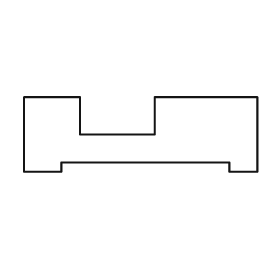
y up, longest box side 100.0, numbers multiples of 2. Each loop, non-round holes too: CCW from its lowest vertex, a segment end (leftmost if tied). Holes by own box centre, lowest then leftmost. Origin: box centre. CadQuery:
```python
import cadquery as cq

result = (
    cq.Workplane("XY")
    .moveTo(-50.0, -16.0)
    .lineTo(-34.0, -16.0)
    .lineTo(-34.0, -12.0)
    .lineTo(38.0, -12.0)
    .lineTo(38.0, -16.0)
    .lineTo(50.0, -16.0)
    .lineTo(50.0, 16.0)
    .lineTo(6.0, 16.0)
    .lineTo(6.0, 0.0)
    .lineTo(-26.0, 0.0)
    .lineTo(-26.0, 16.0)
    .lineTo(-50.0, 16.0)
    .close()
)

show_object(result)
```